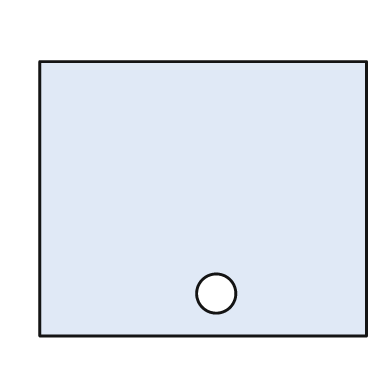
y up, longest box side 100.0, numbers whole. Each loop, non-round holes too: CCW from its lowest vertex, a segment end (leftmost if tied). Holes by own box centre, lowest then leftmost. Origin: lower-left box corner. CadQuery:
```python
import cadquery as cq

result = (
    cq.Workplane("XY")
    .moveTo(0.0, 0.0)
    .lineTo(100.0, 0.0)
    .lineTo(100.0, 84.0)
    .lineTo(0.0, 84.0)
    .close()
    .moveTo(54.0, 13.0)
    .circle(6.0)
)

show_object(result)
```